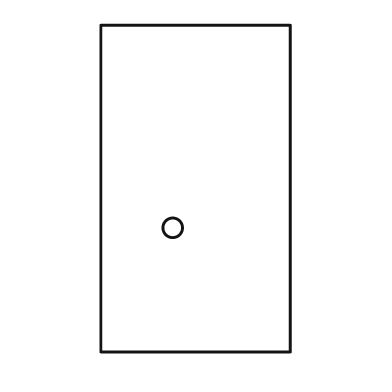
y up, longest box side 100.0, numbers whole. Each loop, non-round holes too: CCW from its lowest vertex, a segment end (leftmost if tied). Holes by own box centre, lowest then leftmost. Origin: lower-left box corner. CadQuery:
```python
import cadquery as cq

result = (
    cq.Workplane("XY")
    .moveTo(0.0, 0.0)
    .lineTo(58.0, 0.0)
    .lineTo(58.0, 100.0)
    .lineTo(0.0, 100.0)
    .close()
    .moveTo(22.0, 38.0)
    .circle(3.0)
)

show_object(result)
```